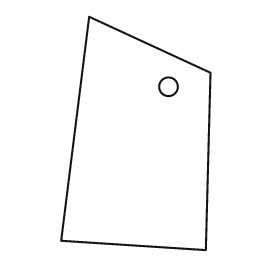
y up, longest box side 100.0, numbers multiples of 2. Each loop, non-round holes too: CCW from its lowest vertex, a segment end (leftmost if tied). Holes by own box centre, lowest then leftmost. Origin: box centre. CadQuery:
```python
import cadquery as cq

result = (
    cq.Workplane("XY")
    .moveTo(30.0, -50.0)
    .lineTo(32.0, 26.0)
    .lineTo(-20.0, 50.0)
    .lineTo(-32.0, -46.0)
    .close()
    .moveTo(14.0, 20.0)
    .circle(4.0)
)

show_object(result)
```